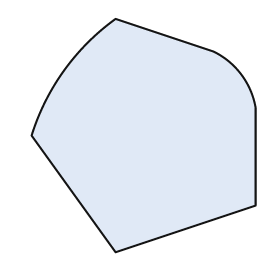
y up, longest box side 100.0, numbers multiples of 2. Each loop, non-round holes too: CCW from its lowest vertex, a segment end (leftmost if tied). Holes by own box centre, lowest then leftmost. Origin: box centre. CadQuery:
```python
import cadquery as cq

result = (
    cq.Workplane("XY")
    .moveTo(-12.0, -50.0)
    .lineTo(48.0, -30.0)
    .lineTo(48.0, 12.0)
    .threePointArc((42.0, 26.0), (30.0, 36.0))
    .lineTo(-12.0, 50.0)
    .threePointArc((-34.0, 28.0), (-48.0, 0.0))
    .close()
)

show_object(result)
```